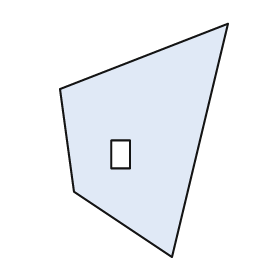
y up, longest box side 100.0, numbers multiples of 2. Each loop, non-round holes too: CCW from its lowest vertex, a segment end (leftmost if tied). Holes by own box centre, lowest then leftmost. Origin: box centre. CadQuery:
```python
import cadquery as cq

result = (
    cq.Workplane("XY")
    .moveTo(12.0, -50.0)
    .lineTo(36.0, 50.0)
    .lineTo(-36.0, 22.0)
    .lineTo(-30.0, -22.0)
    .close()
    .moveTo(-14.0, -12.0)
    .lineTo(-6.0, -12.0)
    .lineTo(-6.0, 0.0)
    .lineTo(-14.0, 0.0)
    .close()
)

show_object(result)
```